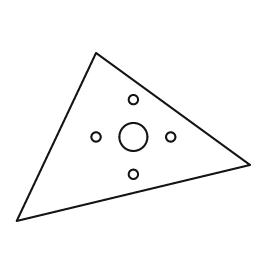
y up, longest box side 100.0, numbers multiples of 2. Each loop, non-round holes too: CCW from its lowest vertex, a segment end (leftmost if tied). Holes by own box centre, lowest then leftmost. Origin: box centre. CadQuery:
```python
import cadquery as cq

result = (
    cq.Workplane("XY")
    .moveTo(-50.0, -36.0)
    .lineTo(50.0, -12.0)
    .lineTo(-16.0, 36.0)
    .close()
    .moveTo(0.0, -16.0)
    .circle(2.0)
    .moveTo(-16.0, 0.0)
    .circle(2.0)
    .moveTo(0.0, 0.0)
    .circle(6.0)
    .moveTo(16.0, 0.0)
    .circle(2.0)
    .moveTo(0.0, 16.0)
    .circle(2.0)
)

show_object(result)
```